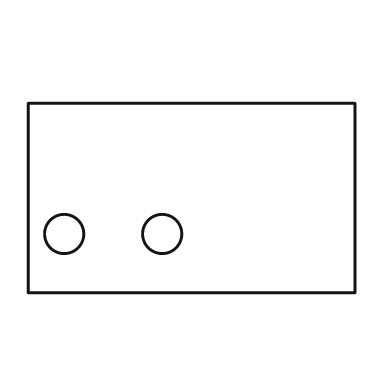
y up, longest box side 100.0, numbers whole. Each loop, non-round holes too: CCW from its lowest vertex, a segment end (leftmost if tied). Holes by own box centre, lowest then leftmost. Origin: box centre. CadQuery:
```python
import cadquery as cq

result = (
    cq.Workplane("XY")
    .moveTo(-50.0, -29.0)
    .lineTo(50.0, -29.0)
    .lineTo(50.0, 29.0)
    .lineTo(-50.0, 29.0)
    .close()
    .moveTo(-39.0, -11.0)
    .circle(6.0)
    .moveTo(-9.0, -11.0)
    .circle(6.0)
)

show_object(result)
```